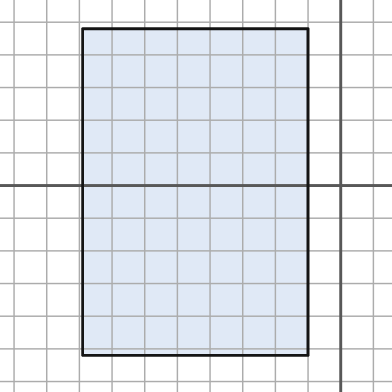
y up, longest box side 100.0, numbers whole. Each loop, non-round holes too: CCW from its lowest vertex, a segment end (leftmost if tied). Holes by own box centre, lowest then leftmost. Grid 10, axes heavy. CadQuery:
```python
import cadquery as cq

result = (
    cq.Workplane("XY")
    .moveTo(-79.0, -52.0)
    .lineTo(-10.0, -52.0)
    .lineTo(-10.0, 48.0)
    .lineTo(-79.0, 48.0)
    .close()
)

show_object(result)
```